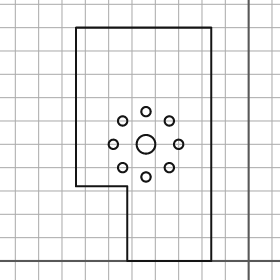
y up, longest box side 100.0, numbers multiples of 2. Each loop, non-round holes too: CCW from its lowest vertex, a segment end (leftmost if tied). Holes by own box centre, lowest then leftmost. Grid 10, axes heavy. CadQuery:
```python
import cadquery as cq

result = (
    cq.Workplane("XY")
    .moveTo(-52.0, 0.0)
    .lineTo(-16.0, 0.0)
    .lineTo(-16.0, 100.0)
    .lineTo(-74.0, 100.0)
    .lineTo(-74.0, 32.0)
    .lineTo(-52.0, 32.0)
    .close()
    .moveTo(-44.0, 36.0)
    .circle(2.0)
    .moveTo(-54.0, 40.0)
    .circle(2.0)
    .moveTo(-34.0, 40.0)
    .circle(2.0)
    .moveTo(-58.0, 50.0)
    .circle(2.0)
    .moveTo(-44.0, 50.0)
    .circle(4.0)
    .moveTo(-30.0, 50.0)
    .circle(2.0)
    .moveTo(-54.0, 60.0)
    .circle(2.0)
    .moveTo(-34.0, 60.0)
    .circle(2.0)
    .moveTo(-44.0, 64.0)
    .circle(2.0)
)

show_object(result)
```